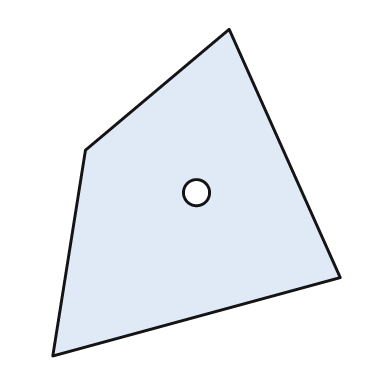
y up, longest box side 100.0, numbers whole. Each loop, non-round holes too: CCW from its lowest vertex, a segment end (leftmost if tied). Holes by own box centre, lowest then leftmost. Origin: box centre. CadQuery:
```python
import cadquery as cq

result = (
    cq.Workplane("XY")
    .moveTo(-44.0, -50.0)
    .lineTo(44.0, -26.0)
    .lineTo(10.0, 50.0)
    .lineTo(-34.0, 13.0)
    .close()
    .moveTo(0.0, 0.0)
    .circle(4.0)
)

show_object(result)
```